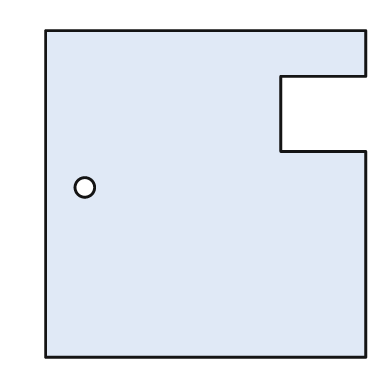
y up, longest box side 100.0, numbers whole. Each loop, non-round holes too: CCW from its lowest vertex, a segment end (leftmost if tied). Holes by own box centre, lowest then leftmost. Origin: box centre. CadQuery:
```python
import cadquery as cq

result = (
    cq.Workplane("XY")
    .moveTo(-49.0, -50.0)
    .lineTo(49.0, -50.0)
    .lineTo(49.0, 13.0)
    .lineTo(23.0, 13.0)
    .lineTo(23.0, 36.0)
    .lineTo(49.0, 36.0)
    .lineTo(49.0, 50.0)
    .lineTo(-49.0, 50.0)
    .close()
    .moveTo(-37.0, 2.0)
    .circle(3.0)
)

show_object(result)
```